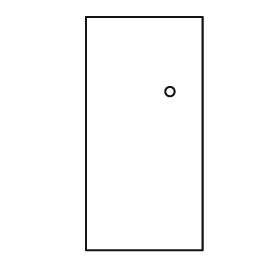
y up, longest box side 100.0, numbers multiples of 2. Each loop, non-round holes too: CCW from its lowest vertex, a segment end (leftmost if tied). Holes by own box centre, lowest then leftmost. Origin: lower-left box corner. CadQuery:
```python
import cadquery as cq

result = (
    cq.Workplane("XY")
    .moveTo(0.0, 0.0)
    .lineTo(50.0, 0.0)
    .lineTo(50.0, 100.0)
    .lineTo(0.0, 100.0)
    .close()
    .moveTo(36.0, 68.0)
    .circle(2.0)
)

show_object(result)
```